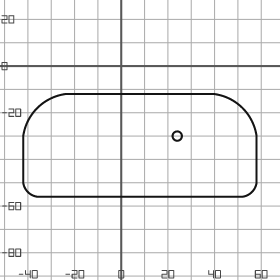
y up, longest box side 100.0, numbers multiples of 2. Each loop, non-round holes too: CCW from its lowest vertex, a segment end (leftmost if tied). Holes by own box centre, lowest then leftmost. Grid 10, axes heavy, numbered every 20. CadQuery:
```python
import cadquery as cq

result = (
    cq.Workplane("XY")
    .moveTo(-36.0, -56.0)
    .lineTo(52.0, -56.0)
    .threePointArc((56.0, -54.0), (58.0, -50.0))
    .lineTo(58.0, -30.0)
    .threePointArc((52.0, -18.0), (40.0, -12.0))
    .lineTo(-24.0, -12.0)
    .threePointArc((-36.0, -18.0), (-42.0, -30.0))
    .lineTo(-42.0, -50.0)
    .threePointArc((-40.0, -54.0), (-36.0, -56.0))
    .close()
    .moveTo(24.0, -30.0)
    .circle(2.0)
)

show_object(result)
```